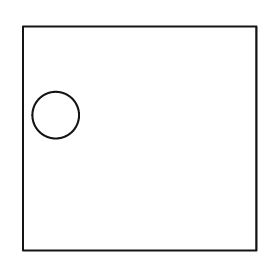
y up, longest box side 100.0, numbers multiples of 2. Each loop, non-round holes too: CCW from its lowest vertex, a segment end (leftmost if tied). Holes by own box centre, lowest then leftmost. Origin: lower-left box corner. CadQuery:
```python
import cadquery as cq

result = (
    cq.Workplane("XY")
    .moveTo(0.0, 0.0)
    .lineTo(100.0, 0.0)
    .lineTo(100.0, 96.0)
    .lineTo(0.0, 96.0)
    .close()
    .moveTo(14.0, 58.0)
    .circle(10.0)
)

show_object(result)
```